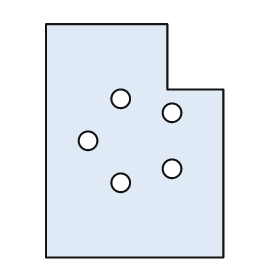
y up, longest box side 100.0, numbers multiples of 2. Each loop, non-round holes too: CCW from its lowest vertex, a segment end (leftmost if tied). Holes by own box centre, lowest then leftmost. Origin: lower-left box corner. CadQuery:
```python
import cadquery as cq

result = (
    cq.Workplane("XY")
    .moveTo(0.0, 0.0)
    .lineTo(76.0, 0.0)
    .lineTo(76.0, 72.0)
    .lineTo(52.0, 72.0)
    .lineTo(52.0, 100.0)
    .lineTo(0.0, 100.0)
    .close()
    .moveTo(32.0, 32.0)
    .circle(4.0)
    .moveTo(54.0, 38.0)
    .circle(4.0)
    .moveTo(18.0, 50.0)
    .circle(4.0)
    .moveTo(54.0, 62.0)
    .circle(4.0)
    .moveTo(32.0, 68.0)
    .circle(4.0)
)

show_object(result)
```